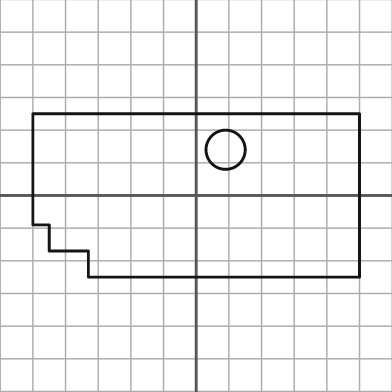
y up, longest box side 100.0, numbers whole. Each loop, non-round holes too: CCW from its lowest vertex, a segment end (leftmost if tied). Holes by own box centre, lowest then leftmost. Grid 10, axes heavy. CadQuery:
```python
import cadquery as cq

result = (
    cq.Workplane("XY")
    .moveTo(-33.0, -25.0)
    .lineTo(50.0, -25.0)
    .lineTo(50.0, 25.0)
    .lineTo(-50.0, 25.0)
    .lineTo(-50.0, -9.0)
    .lineTo(-45.0, -9.0)
    .lineTo(-45.0, -17.0)
    .lineTo(-33.0, -17.0)
    .close()
    .moveTo(9.0, 14.0)
    .circle(6.0)
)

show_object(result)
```